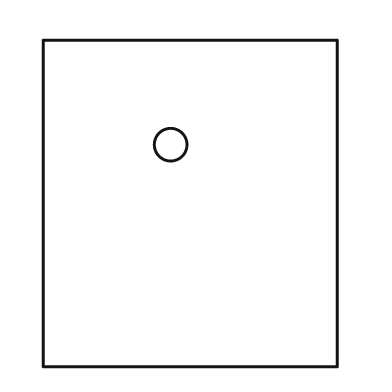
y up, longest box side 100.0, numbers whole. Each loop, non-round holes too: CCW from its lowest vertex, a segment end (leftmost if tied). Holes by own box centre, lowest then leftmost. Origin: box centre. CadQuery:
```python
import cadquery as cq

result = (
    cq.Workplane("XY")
    .moveTo(-45.0, -50.0)
    .lineTo(45.0, -50.0)
    .lineTo(45.0, 50.0)
    .lineTo(-45.0, 50.0)
    .close()
    .moveTo(-6.0, 18.0)
    .circle(5.0)
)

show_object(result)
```